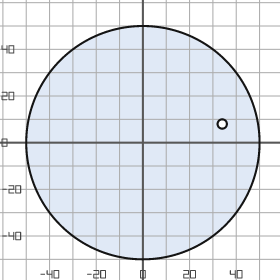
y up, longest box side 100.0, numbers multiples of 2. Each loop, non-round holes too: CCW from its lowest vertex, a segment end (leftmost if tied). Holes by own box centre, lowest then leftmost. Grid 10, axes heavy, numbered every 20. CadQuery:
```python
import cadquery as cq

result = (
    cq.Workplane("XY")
    .moveTo(0.0, 0.0)
    .circle(50.0)
    .moveTo(34.0, 8.0)
    .circle(2.0)
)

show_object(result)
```